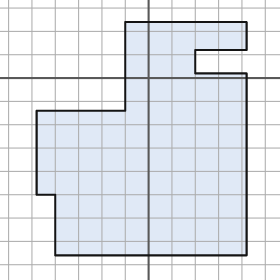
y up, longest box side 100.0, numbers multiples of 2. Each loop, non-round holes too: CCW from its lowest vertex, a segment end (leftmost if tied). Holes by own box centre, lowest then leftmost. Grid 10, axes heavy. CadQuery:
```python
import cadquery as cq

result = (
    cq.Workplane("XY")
    .moveTo(-40.0, -76.0)
    .lineTo(42.0, -76.0)
    .lineTo(42.0, 2.0)
    .lineTo(20.0, 2.0)
    .lineTo(20.0, 12.0)
    .lineTo(42.0, 12.0)
    .lineTo(42.0, 24.0)
    .lineTo(-10.0, 24.0)
    .lineTo(-10.0, -14.0)
    .lineTo(-48.0, -14.0)
    .lineTo(-48.0, -50.0)
    .lineTo(-40.0, -50.0)
    .close()
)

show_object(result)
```